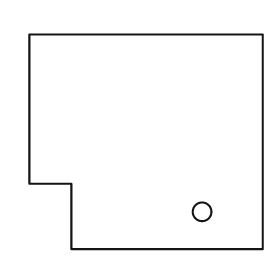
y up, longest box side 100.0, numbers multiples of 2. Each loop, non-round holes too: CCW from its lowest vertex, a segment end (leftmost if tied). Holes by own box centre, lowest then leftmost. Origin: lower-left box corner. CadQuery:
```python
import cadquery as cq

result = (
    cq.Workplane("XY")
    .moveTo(18.0, 0.0)
    .lineTo(100.0, 0.0)
    .lineTo(100.0, 92.0)
    .lineTo(0.0, 92.0)
    .lineTo(0.0, 28.0)
    .lineTo(18.0, 28.0)
    .close()
    .moveTo(74.0, 16.0)
    .circle(4.0)
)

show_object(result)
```